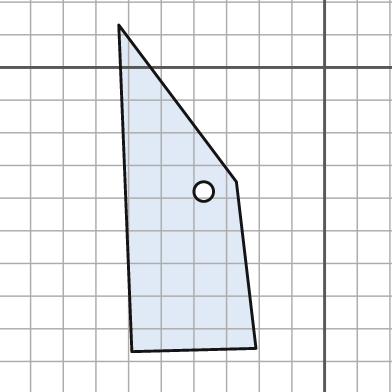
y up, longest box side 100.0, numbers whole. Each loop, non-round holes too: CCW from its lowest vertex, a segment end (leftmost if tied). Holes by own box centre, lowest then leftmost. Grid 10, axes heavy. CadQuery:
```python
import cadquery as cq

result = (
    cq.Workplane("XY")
    .moveTo(-59.0, -87.0)
    .lineTo(-21.0, -86.0)
    .lineTo(-27.0, -35.0)
    .lineTo(-63.0, 13.0)
    .close()
    .moveTo(-37.0, -38.0)
    .circle(3.0)
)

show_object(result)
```